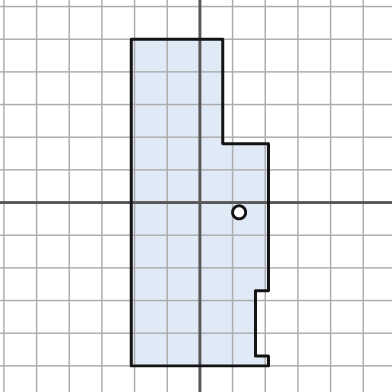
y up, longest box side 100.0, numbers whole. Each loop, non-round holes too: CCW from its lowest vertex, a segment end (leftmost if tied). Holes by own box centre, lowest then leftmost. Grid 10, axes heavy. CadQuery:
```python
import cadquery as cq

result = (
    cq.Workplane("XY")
    .moveTo(-21.0, -50.0)
    .lineTo(21.0, -50.0)
    .lineTo(21.0, -47.0)
    .lineTo(17.0, -47.0)
    .lineTo(17.0, -27.0)
    .lineTo(21.0, -27.0)
    .lineTo(21.0, 18.0)
    .lineTo(7.0, 18.0)
    .lineTo(7.0, 50.0)
    .lineTo(-21.0, 50.0)
    .close()
    .moveTo(12.0, -3.0)
    .circle(2.0)
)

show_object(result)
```